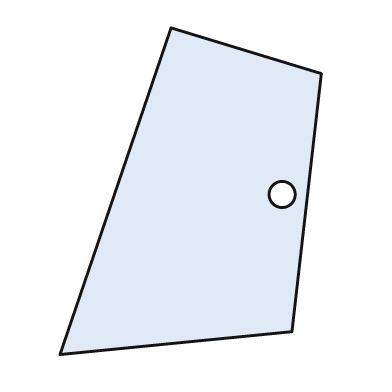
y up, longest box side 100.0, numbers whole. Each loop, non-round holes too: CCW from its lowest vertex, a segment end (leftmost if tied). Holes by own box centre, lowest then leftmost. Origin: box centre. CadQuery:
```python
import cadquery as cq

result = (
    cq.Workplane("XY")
    .moveTo(-40.0, -50.0)
    .lineTo(31.0, -43.0)
    .lineTo(40.0, 36.0)
    .lineTo(-6.0, 50.0)
    .close()
    .moveTo(28.0, -1.0)
    .circle(4.0)
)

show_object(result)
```